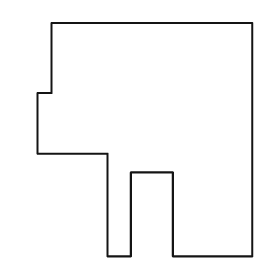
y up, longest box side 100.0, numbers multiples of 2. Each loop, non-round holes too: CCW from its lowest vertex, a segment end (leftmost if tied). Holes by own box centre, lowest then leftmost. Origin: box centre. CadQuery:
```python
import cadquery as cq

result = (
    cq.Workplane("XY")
    .moveTo(-16.0, -50.0)
    .lineTo(-6.0, -50.0)
    .lineTo(-6.0, -14.0)
    .lineTo(12.0, -14.0)
    .lineTo(12.0, -50.0)
    .lineTo(46.0, -50.0)
    .lineTo(46.0, 50.0)
    .lineTo(-40.0, 50.0)
    .lineTo(-40.0, 20.0)
    .lineTo(-46.0, 20.0)
    .lineTo(-46.0, -6.0)
    .lineTo(-16.0, -6.0)
    .close()
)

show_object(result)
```